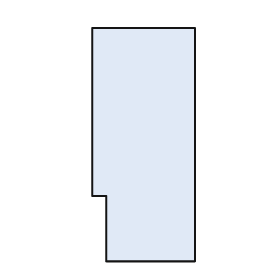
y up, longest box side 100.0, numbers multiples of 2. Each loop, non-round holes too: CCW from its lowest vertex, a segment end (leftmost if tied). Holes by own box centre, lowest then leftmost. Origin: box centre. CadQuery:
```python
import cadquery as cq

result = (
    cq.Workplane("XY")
    .moveTo(-16.0, -50.0)
    .lineTo(22.0, -50.0)
    .lineTo(22.0, 50.0)
    .lineTo(-22.0, 50.0)
    .lineTo(-22.0, -22.0)
    .lineTo(-16.0, -22.0)
    .close()
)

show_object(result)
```